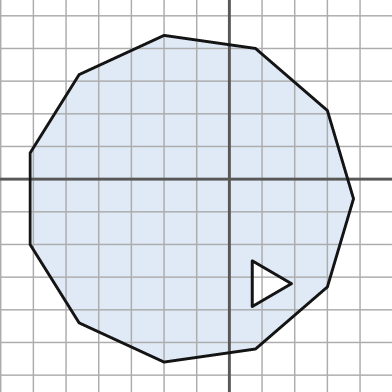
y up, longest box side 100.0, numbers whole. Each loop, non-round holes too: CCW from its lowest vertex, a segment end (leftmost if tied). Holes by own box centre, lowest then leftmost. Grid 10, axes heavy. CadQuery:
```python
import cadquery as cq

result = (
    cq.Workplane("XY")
    .moveTo(-20.0, -56.0)
    .lineTo(8.0, -52.0)
    .lineTo(30.0, -33.0)
    .lineTo(38.0, -6.0)
    .lineTo(30.0, 21.0)
    .lineTo(8.0, 40.0)
    .lineTo(-20.0, 44.0)
    .lineTo(-46.0, 32.0)
    .lineTo(-61.0, 8.0)
    .lineTo(-61.0, -20.0)
    .lineTo(-46.0, -44.0)
    .close()
    .moveTo(7.0, -39.0)
    .lineTo(19.0, -32.0)
    .lineTo(7.0, -25.0)
    .close()
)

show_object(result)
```